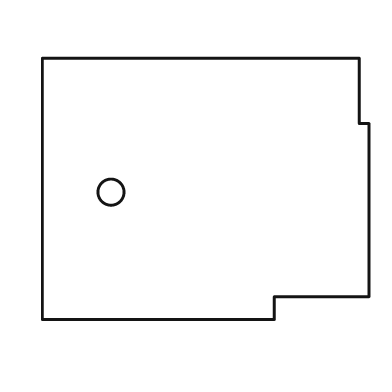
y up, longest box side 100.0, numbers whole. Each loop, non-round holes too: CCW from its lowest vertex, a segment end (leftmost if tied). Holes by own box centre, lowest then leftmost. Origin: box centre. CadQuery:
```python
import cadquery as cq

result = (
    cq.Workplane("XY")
    .moveTo(-50.0, -40.0)
    .lineTo(21.0, -40.0)
    .lineTo(21.0, -33.0)
    .lineTo(50.0, -33.0)
    .lineTo(50.0, 20.0)
    .lineTo(47.0, 20.0)
    .lineTo(47.0, 40.0)
    .lineTo(-50.0, 40.0)
    .close()
    .moveTo(-29.0, -1.0)
    .circle(4.0)
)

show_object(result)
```